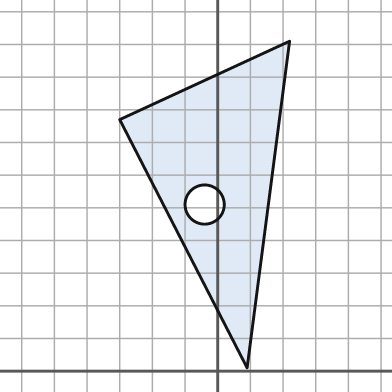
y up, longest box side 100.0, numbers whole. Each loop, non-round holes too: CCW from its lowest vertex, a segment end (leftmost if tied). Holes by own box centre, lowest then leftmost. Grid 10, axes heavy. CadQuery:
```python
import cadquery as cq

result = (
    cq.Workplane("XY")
    .moveTo(9.0, 1.0)
    .lineTo(22.0, 101.0)
    .lineTo(-30.0, 77.0)
    .close()
    .moveTo(-4.0, 51.0)
    .circle(6.0)
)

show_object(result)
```